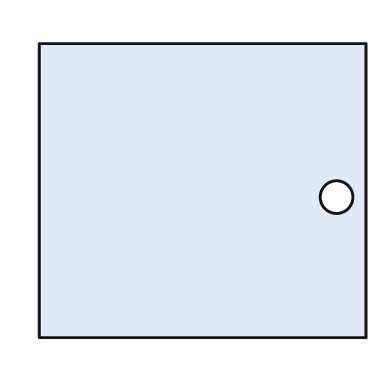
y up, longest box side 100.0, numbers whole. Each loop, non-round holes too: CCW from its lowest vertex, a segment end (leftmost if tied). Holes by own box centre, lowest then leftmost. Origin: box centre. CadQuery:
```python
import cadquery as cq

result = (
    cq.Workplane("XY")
    .moveTo(-50.0, -45.0)
    .lineTo(50.0, -45.0)
    .lineTo(50.0, 45.0)
    .lineTo(-50.0, 45.0)
    .close()
    .moveTo(41.0, -2.0)
    .circle(5.0)
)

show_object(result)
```